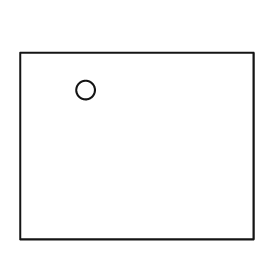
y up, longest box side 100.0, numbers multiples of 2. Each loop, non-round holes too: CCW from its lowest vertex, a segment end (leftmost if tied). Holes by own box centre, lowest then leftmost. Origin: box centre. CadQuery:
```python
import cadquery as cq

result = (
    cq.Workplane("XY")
    .moveTo(-50.0, -40.0)
    .lineTo(50.0, -40.0)
    .lineTo(50.0, 40.0)
    .lineTo(-50.0, 40.0)
    .close()
    .moveTo(-22.0, 24.0)
    .circle(4.0)
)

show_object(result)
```